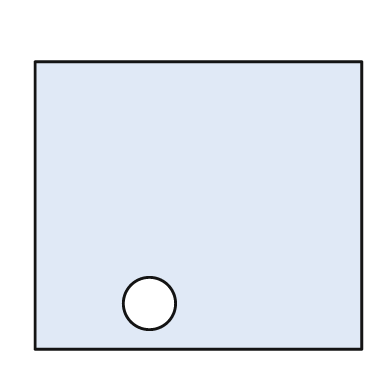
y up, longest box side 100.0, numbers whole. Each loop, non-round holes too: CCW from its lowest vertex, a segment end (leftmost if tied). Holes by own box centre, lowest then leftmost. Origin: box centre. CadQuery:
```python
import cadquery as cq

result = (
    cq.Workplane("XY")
    .moveTo(-50.0, -44.0)
    .lineTo(50.0, -44.0)
    .lineTo(50.0, 44.0)
    .lineTo(-50.0, 44.0)
    .close()
    .moveTo(-15.0, -30.0)
    .circle(8.0)
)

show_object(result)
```